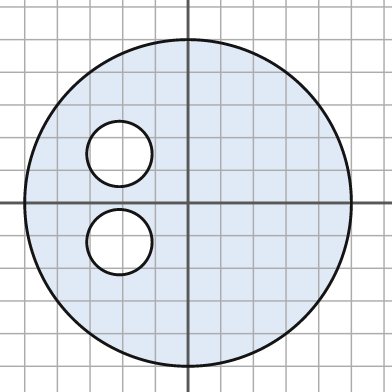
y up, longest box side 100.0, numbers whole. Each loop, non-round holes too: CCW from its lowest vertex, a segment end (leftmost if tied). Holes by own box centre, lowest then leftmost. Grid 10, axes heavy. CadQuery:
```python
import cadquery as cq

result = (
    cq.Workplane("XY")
    .moveTo(0.0, 0.0)
    .circle(50.0)
    .moveTo(-21.0, -12.0)
    .circle(10.0)
    .moveTo(-21.0, 15.0)
    .circle(10.0)
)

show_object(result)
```